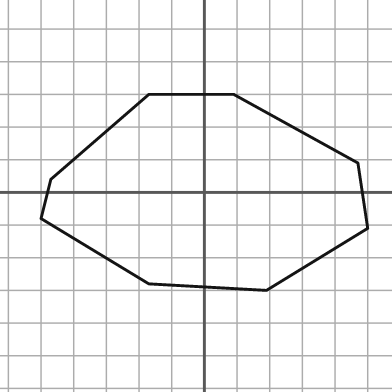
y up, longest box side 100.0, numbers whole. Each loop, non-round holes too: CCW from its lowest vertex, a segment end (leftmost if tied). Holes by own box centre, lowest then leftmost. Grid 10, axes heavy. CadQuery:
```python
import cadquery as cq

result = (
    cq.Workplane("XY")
    .moveTo(19.0, -30.0)
    .lineTo(50.0, -11.0)
    .lineTo(47.0, 9.0)
    .lineTo(9.0, 30.0)
    .lineTo(-17.0, 30.0)
    .lineTo(-47.0, 4.0)
    .lineTo(-50.0, -8.0)
    .lineTo(-17.0, -28.0)
    .close()
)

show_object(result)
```